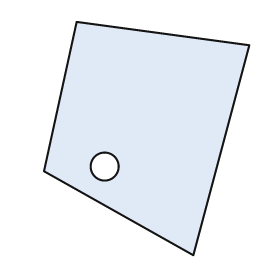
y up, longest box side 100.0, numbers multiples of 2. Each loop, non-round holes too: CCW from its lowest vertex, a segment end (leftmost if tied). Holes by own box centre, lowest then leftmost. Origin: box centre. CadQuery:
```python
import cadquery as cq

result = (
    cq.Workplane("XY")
    .moveTo(20.0, -50.0)
    .lineTo(44.0, 40.0)
    .lineTo(-30.0, 50.0)
    .lineTo(-44.0, -14.0)
    .close()
    .moveTo(-18.0, -12.0)
    .circle(6.0)
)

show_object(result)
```